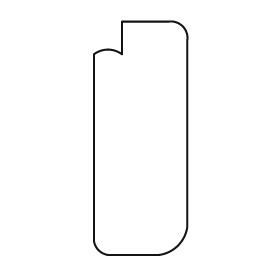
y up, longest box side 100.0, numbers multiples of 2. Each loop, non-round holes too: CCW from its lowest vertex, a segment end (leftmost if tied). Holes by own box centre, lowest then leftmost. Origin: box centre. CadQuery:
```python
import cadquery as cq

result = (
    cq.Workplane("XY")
    .moveTo(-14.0, -50.0)
    .lineTo(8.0, -50.0)
    .threePointArc((16.0, -46.0), (20.0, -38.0))
    .lineTo(20.0, 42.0)
    .threePointArc((18.0, 48.0), (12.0, 50.0))
    .lineTo(-8.0, 50.0)
    .lineTo(-8.0, 36.0)
    .threePointArc((-14.0, 38.0), (-20.0, 36.0))
    .lineTo(-20.0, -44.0)
    .threePointArc((-18.0, -48.0), (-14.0, -50.0))
    .close()
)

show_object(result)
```